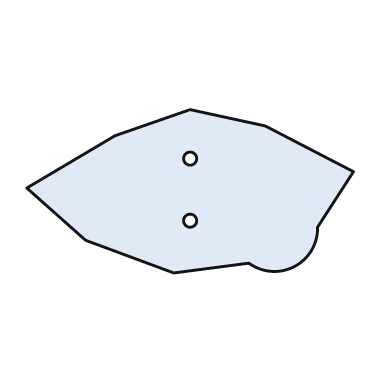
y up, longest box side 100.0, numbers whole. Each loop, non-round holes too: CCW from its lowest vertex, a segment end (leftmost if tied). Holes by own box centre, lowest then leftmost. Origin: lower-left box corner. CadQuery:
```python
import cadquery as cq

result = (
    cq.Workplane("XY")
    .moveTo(45.0, 0.0)
    .lineTo(68.0, 3.0)
    .threePointArc((82.0, 2.0), (89.0, 14.0))
    .lineTo(100.0, 31.0)
    .lineTo(73.0, 45.0)
    .lineTo(50.0, 50.0)
    .lineTo(27.0, 42.0)
    .lineTo(0.0, 26.0)
    .lineTo(18.0, 10.0)
    .close()
    .moveTo(50.0, 16.0)
    .circle(2.0)
    .moveTo(50.0, 35.0)
    .circle(2.0)
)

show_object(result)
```